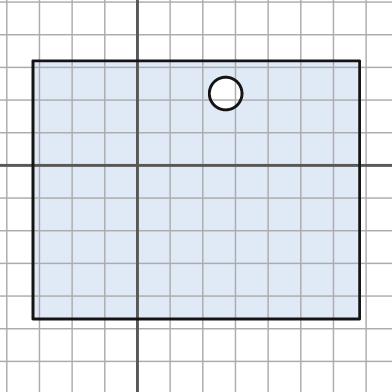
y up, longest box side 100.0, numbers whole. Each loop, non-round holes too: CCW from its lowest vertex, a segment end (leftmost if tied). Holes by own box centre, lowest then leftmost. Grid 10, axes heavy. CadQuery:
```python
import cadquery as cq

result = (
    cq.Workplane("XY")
    .moveTo(-32.0, -47.0)
    .lineTo(68.0, -47.0)
    .lineTo(68.0, 32.0)
    .lineTo(-32.0, 32.0)
    .close()
    .moveTo(27.0, 22.0)
    .circle(5.0)
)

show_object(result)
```